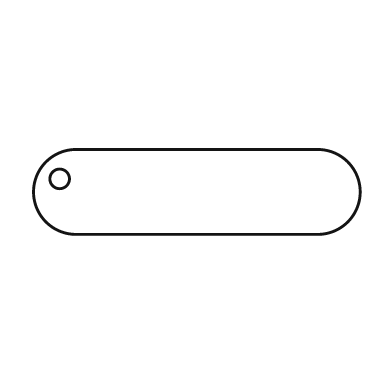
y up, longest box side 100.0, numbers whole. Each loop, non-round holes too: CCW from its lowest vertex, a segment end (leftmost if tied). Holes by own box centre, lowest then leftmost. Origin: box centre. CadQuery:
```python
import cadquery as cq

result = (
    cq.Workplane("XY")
    .moveTo(-37.0, -13.0)
    .lineTo(37.0, -13.0)
    .threePointArc((50.0, 0.0), (37.0, 13.0))
    .lineTo(-37.0, 13.0)
    .threePointArc((-50.0, 0.0), (-37.0, -13.0))
    .close()
    .moveTo(-42.0, 4.0)
    .circle(3.0)
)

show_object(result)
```